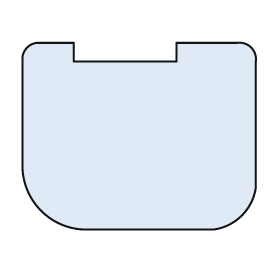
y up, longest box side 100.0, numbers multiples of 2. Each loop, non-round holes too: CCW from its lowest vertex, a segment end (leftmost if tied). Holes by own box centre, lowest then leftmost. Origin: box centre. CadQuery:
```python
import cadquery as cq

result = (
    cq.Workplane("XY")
    .moveTo(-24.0, -40.0)
    .lineTo(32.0, -40.0)
    .threePointArc((44.0, -34.0), (50.0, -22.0))
    .lineTo(50.0, 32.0)
    .threePointArc((48.0, 38.0), (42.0, 40.0))
    .lineTo(16.0, 40.0)
    .lineTo(16.0, 32.0)
    .lineTo(-28.0, 32.0)
    .lineTo(-28.0, 40.0)
    .lineTo(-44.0, 40.0)
    .threePointArc((-48.0, 38.0), (-50.0, 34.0))
    .lineTo(-50.0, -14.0)
    .threePointArc((-42.0, -32.0), (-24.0, -40.0))
    .close()
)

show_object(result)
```